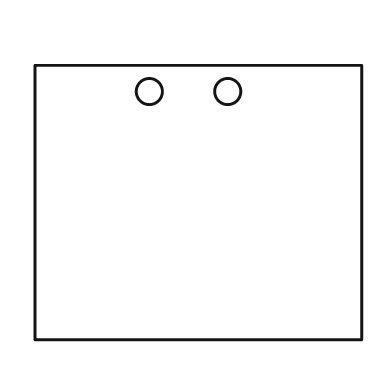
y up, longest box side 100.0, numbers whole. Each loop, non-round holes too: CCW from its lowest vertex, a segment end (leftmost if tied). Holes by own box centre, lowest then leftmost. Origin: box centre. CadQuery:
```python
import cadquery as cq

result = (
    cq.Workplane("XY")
    .moveTo(-50.0, -42.0)
    .lineTo(50.0, -42.0)
    .lineTo(50.0, 42.0)
    .lineTo(-50.0, 42.0)
    .close()
    .moveTo(-15.0, 34.0)
    .circle(4.0)
    .moveTo(9.0, 34.0)
    .circle(4.0)
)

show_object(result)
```